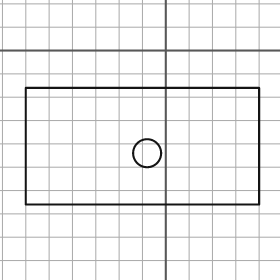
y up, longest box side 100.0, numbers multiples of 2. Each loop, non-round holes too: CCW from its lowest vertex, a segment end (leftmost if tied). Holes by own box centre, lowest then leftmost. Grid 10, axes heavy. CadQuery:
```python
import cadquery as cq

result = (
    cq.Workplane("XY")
    .moveTo(-60.0, -66.0)
    .lineTo(40.0, -66.0)
    .lineTo(40.0, -16.0)
    .lineTo(-60.0, -16.0)
    .close()
    .moveTo(-8.0, -44.0)
    .circle(6.0)
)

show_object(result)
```